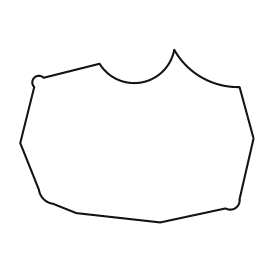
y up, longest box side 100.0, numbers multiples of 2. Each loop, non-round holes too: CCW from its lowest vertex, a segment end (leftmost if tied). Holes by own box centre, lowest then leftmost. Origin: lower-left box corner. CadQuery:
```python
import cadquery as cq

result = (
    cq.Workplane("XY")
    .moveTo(60.0, 0.0)
    .lineTo(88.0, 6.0)
    .threePointArc((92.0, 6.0), (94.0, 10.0))
    .lineTo(100.0, 36.0)
    .lineTo(94.0, 58.0)
    .threePointArc((78.0, 62.0), (66.0, 74.0))
    .threePointArc((52.0, 60.0), (34.0, 68.0))
    .lineTo(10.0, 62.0)
    .threePointArc((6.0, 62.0), (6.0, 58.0))
    .lineTo(0.0, 34.0)
    .lineTo(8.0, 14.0)
    .threePointArc((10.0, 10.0), (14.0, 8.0))
    .lineTo(24.0, 4.0)
    .close()
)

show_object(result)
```